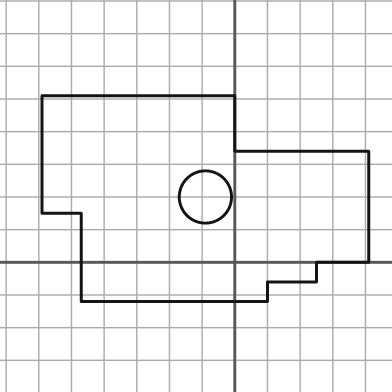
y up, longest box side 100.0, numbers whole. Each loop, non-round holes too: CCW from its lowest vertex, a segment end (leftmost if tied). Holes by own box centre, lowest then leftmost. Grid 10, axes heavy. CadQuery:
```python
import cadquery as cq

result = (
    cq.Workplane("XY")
    .moveTo(-47.0, -12.0)
    .lineTo(10.0, -12.0)
    .lineTo(10.0, -6.0)
    .lineTo(25.0, -6.0)
    .lineTo(25.0, 0.0)
    .lineTo(41.0, 0.0)
    .lineTo(41.0, 34.0)
    .lineTo(0.0, 34.0)
    .lineTo(0.0, 51.0)
    .lineTo(-59.0, 51.0)
    .lineTo(-59.0, 15.0)
    .lineTo(-47.0, 15.0)
    .close()
    .moveTo(-9.0, 20.0)
    .circle(8.0)
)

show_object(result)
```